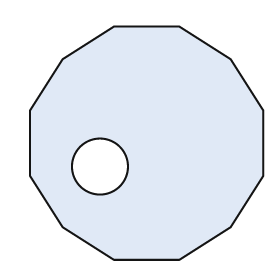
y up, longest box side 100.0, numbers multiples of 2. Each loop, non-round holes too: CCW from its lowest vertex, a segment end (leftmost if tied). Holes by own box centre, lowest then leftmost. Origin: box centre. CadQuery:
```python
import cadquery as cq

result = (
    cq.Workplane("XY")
    .moveTo(-14.0, -50.0)
    .lineTo(14.0, -50.0)
    .lineTo(36.0, -36.0)
    .lineTo(50.0, -14.0)
    .lineTo(50.0, 14.0)
    .lineTo(36.0, 36.0)
    .lineTo(14.0, 50.0)
    .lineTo(-14.0, 50.0)
    .lineTo(-36.0, 36.0)
    .lineTo(-50.0, 14.0)
    .lineTo(-50.0, -14.0)
    .lineTo(-36.0, -36.0)
    .close()
    .moveTo(-20.0, -10.0)
    .circle(12.0)
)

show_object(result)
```